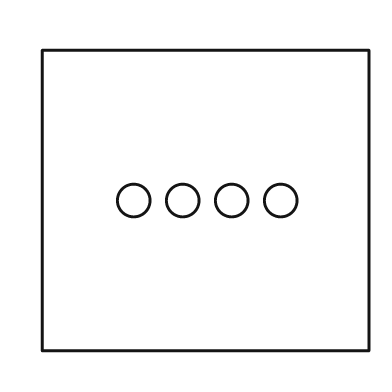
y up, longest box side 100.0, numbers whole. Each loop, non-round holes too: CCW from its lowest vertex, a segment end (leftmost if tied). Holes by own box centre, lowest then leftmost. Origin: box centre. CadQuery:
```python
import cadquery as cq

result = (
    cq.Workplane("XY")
    .moveTo(-50.0, -46.0)
    .lineTo(50.0, -46.0)
    .lineTo(50.0, 46.0)
    .lineTo(-50.0, 46.0)
    .close()
    .moveTo(-22.0, 0.0)
    .circle(5.0)
    .moveTo(-7.0, 0.0)
    .circle(5.0)
    .moveTo(8.0, 0.0)
    .circle(5.0)
    .moveTo(23.0, 0.0)
    .circle(5.0)
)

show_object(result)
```